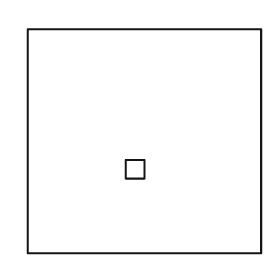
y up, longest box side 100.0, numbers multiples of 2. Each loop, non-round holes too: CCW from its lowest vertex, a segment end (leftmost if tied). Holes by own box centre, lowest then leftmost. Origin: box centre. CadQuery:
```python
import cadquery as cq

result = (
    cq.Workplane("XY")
    .moveTo(-50.0, -48.0)
    .lineTo(50.0, -48.0)
    .lineTo(50.0, 48.0)
    .lineTo(-50.0, 48.0)
    .close()
    .moveTo(-8.0, -16.0)
    .lineTo(0.0, -16.0)
    .lineTo(0.0, -8.0)
    .lineTo(-8.0, -8.0)
    .close()
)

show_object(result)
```